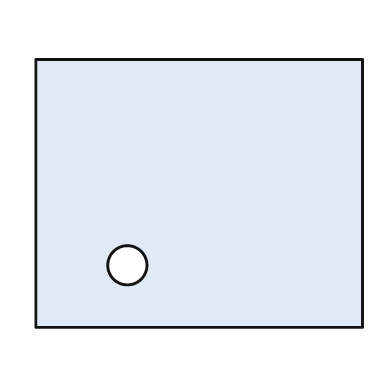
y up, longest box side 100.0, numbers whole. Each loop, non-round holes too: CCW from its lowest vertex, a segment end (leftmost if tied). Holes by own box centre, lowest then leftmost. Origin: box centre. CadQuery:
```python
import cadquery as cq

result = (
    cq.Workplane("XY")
    .moveTo(-50.0, -41.0)
    .lineTo(50.0, -41.0)
    .lineTo(50.0, 41.0)
    .lineTo(-50.0, 41.0)
    .close()
    .moveTo(-22.0, -22.0)
    .circle(6.0)
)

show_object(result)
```